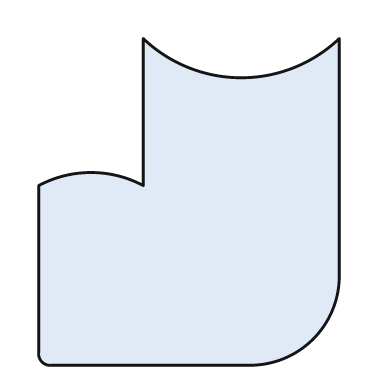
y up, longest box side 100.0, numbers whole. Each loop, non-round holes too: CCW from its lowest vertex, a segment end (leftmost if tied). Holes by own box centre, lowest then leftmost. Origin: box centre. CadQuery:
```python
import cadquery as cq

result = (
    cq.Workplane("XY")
    .moveTo(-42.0, -50.0)
    .lineTo(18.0, -50.0)
    .threePointArc((38.0, -42.0), (46.0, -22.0))
    .lineTo(46.0, 50.0)
    .threePointArc((16.0, 38.0), (-14.0, 50.0))
    .lineTo(-14.0, 5.0)
    .threePointArc((-30.0, 9.0), (-46.0, 5.0))
    .lineTo(-46.0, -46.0)
    .threePointArc((-45.0, -49.0), (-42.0, -50.0))
    .close()
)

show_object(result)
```